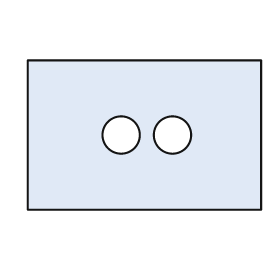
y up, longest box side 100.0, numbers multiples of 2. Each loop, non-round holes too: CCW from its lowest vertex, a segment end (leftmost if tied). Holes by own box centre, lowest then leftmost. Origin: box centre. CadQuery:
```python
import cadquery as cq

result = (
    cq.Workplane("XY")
    .moveTo(-50.0, -32.0)
    .lineTo(50.0, -32.0)
    .lineTo(50.0, 32.0)
    .lineTo(-50.0, 32.0)
    .close()
    .moveTo(-10.0, 0.0)
    .circle(8.0)
    .moveTo(12.0, 0.0)
    .circle(8.0)
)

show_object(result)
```